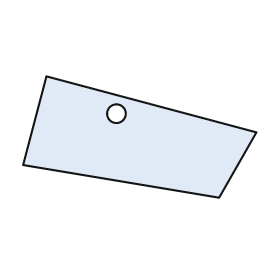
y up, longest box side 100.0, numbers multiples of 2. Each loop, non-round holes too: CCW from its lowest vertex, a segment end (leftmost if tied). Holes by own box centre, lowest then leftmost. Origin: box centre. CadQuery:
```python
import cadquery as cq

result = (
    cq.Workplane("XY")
    .moveTo(34.0, -26.0)
    .lineTo(50.0, 2.0)
    .lineTo(-40.0, 26.0)
    .lineTo(-50.0, -12.0)
    .close()
    .moveTo(-10.0, 10.0)
    .circle(4.0)
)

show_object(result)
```